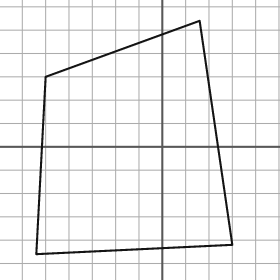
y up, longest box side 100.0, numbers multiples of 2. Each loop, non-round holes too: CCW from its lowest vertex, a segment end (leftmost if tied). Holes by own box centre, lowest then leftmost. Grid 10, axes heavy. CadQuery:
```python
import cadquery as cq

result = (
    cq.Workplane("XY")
    .moveTo(-54.0, -46.0)
    .lineTo(30.0, -42.0)
    .lineTo(16.0, 54.0)
    .lineTo(-50.0, 30.0)
    .close()
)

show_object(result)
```